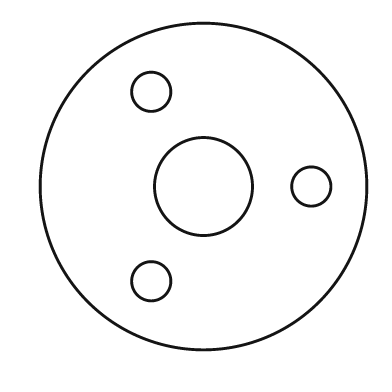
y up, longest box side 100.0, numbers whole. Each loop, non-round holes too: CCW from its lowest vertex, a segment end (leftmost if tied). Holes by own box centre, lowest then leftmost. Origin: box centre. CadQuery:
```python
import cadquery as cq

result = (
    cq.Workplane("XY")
    .moveTo(0.0, 0.0)
    .circle(50.0)
    .moveTo(-16.0, -29.0)
    .circle(6.0)
    .moveTo(0.0, 0.0)
    .circle(15.0)
    .moveTo(33.0, 0.0)
    .circle(6.0)
    .moveTo(-16.0, 29.0)
    .circle(6.0)
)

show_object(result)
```